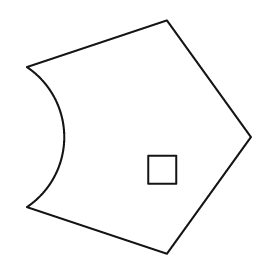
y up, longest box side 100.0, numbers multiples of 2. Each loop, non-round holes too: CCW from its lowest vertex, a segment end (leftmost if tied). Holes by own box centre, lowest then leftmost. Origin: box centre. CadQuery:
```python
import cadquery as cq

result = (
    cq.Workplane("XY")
    .moveTo(12.0, -50.0)
    .lineTo(48.0, 0.0)
    .lineTo(12.0, 50.0)
    .lineTo(-48.0, 30.0)
    .threePointArc((-32.0, 0.0), (-48.0, -30.0))
    .close()
    .moveTo(4.0, -20.0)
    .lineTo(16.0, -20.0)
    .lineTo(16.0, -8.0)
    .lineTo(4.0, -8.0)
    .close()
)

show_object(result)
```